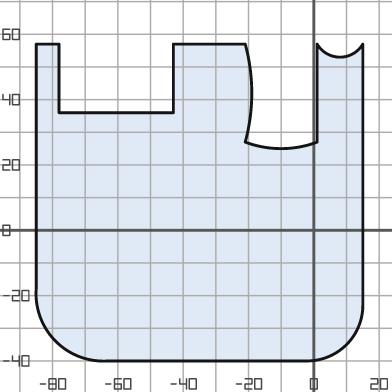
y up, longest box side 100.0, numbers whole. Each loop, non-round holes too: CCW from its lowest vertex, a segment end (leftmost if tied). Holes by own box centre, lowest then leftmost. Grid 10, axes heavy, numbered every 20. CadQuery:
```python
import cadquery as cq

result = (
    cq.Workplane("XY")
    .moveTo(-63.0, -40.0)
    .lineTo(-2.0, -40.0)
    .threePointArc((10.0, -35.0), (15.0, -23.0))
    .lineTo(15.0, 57.0)
    .threePointArc((8.0, 53.0), (1.0, 57.0))
    .lineTo(1.0, 27.0)
    .threePointArc((-10.0, 25.0), (-21.0, 27.0))
    .threePointArc((-19.0, 42.0), (-21.0, 57.0))
    .lineTo(-43.0, 57.0)
    .lineTo(-43.0, 36.0)
    .lineTo(-78.0, 36.0)
    .lineTo(-78.0, 57.0)
    .lineTo(-85.0, 57.0)
    .lineTo(-85.0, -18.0)
    .threePointArc((-79.0, -34.0), (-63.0, -40.0))
    .close()
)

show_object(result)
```